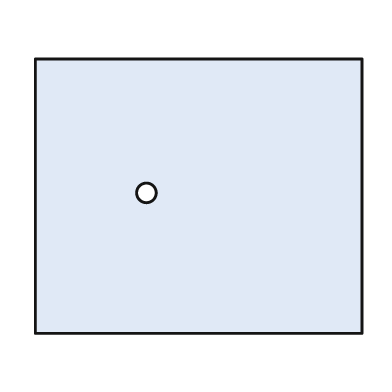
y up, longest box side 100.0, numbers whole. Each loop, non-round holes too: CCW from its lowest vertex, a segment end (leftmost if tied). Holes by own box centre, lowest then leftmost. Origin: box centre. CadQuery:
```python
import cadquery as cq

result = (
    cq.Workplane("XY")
    .moveTo(-50.0, -42.0)
    .lineTo(50.0, -42.0)
    .lineTo(50.0, 42.0)
    .lineTo(-50.0, 42.0)
    .close()
    .moveTo(-16.0, 1.0)
    .circle(3.0)
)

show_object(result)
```